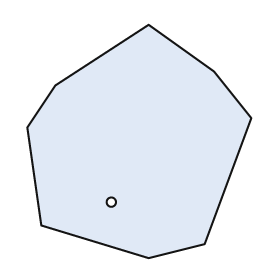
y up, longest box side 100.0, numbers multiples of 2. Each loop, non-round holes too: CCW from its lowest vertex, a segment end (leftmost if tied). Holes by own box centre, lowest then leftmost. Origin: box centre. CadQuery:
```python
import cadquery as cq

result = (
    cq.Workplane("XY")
    .moveTo(4.0, -50.0)
    .lineTo(28.0, -44.0)
    .lineTo(48.0, 10.0)
    .lineTo(32.0, 30.0)
    .lineTo(4.0, 50.0)
    .lineTo(-36.0, 24.0)
    .lineTo(-48.0, 6.0)
    .lineTo(-42.0, -36.0)
    .close()
    .moveTo(-12.0, -26.0)
    .circle(2.0)
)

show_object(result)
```